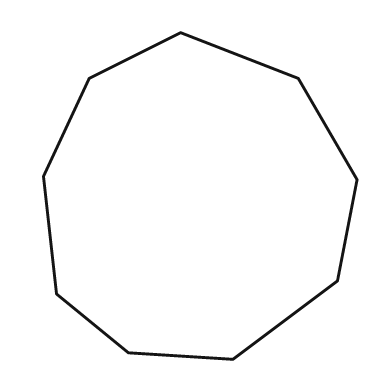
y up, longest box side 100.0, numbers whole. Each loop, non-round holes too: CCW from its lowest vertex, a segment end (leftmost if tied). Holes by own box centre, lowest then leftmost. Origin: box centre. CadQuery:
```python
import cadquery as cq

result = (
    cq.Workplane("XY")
    .moveTo(10.0, -50.0)
    .lineTo(42.0, -26.0)
    .lineTo(48.0, 5.0)
    .lineTo(30.0, 36.0)
    .lineTo(-6.0, 50.0)
    .lineTo(-34.0, 36.0)
    .lineTo(-48.0, 6.0)
    .lineTo(-44.0, -30.0)
    .lineTo(-22.0, -48.0)
    .close()
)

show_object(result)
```